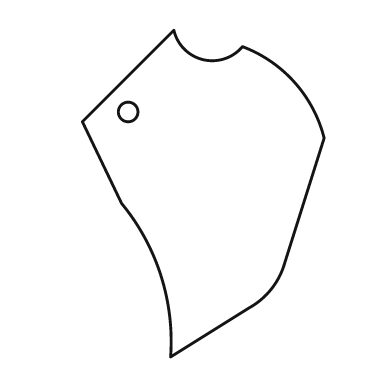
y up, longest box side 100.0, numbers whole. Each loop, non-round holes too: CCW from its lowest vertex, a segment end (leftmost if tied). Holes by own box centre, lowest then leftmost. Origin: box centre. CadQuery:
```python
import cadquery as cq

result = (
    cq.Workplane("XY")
    .moveTo(-10.0, -50.0)
    .lineTo(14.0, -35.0)
    .threePointArc((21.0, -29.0), (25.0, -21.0))
    .lineTo(37.0, 17.0)
    .threePointArc((28.0, 34.0), (12.0, 45.0))
    .threePointArc((0.0, 41.0), (-9.0, 50.0))
    .lineTo(-37.0, 22.0)
    .lineTo(-25.0, -3.0)
    .threePointArc((-13.0, -25.0), (-10.0, -50.0))
    .close()
    .moveTo(-23.0, 25.0)
    .circle(3.0)
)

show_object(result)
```